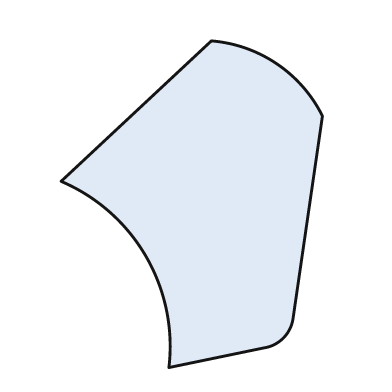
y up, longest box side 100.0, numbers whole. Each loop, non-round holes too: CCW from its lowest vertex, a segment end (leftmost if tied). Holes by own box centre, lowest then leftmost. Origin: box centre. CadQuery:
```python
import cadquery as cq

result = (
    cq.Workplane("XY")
    .moveTo(-7.0, -50.0)
    .lineTo(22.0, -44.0)
    .threePointArc((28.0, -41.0), (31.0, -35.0))
    .lineTo(40.0, 27.0)
    .threePointArc((26.0, 43.0), (6.0, 50.0))
    .lineTo(-40.0, 7.0)
    .threePointArc((-14.0, -16.0), (-7.0, -50.0))
    .close()
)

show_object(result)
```